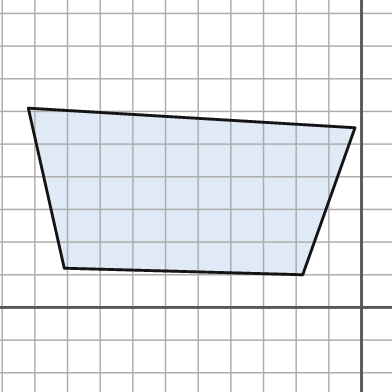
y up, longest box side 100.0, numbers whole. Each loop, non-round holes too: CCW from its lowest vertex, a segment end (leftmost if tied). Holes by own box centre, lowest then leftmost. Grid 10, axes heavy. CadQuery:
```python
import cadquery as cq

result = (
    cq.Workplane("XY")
    .moveTo(-18.0, 10.0)
    .lineTo(-2.0, 55.0)
    .lineTo(-102.0, 61.0)
    .lineTo(-91.0, 12.0)
    .close()
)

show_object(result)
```